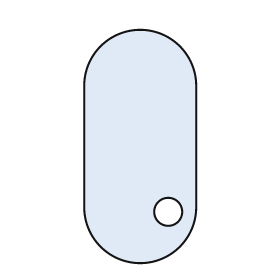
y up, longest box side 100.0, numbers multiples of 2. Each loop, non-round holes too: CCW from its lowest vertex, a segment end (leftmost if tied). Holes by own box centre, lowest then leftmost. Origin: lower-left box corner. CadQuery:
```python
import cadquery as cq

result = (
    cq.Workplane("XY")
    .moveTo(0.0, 24.0)
    .threePointArc((24.0, 0.0), (48.0, 24.0))
    .lineTo(48.0, 76.0)
    .threePointArc((24.0, 100.0), (0.0, 76.0))
    .close()
    .moveTo(36.0, 22.0)
    .circle(6.0)
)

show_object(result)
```